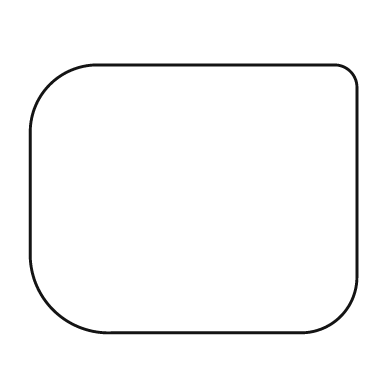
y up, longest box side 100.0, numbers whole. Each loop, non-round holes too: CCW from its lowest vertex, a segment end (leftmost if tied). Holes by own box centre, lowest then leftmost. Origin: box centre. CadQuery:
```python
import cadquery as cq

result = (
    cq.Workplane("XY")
    .moveTo(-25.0, -41.0)
    .lineTo(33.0, -41.0)
    .threePointArc((45.0, -36.0), (50.0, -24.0))
    .lineTo(50.0, 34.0)
    .threePointArc((48.0, 39.0), (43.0, 41.0))
    .lineTo(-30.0, 41.0)
    .threePointArc((-44.0, 35.0), (-50.0, 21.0))
    .lineTo(-50.0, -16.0)
    .threePointArc((-43.0, -34.0), (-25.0, -41.0))
    .close()
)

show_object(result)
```